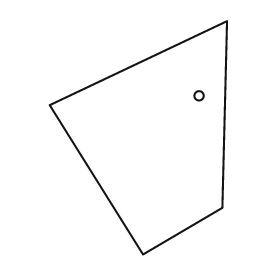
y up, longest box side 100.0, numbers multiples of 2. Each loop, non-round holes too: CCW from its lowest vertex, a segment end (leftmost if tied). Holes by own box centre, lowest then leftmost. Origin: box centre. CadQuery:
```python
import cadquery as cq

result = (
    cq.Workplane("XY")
    .moveTo(2.0, -50.0)
    .lineTo(36.0, -30.0)
    .lineTo(38.0, 50.0)
    .lineTo(-38.0, 14.0)
    .close()
    .moveTo(26.0, 18.0)
    .circle(2.0)
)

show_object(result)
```